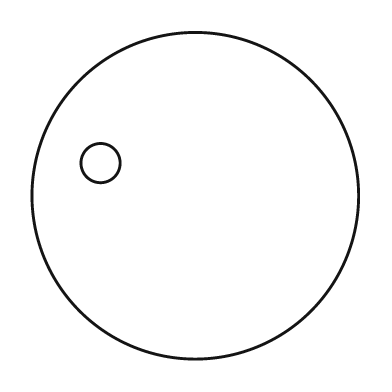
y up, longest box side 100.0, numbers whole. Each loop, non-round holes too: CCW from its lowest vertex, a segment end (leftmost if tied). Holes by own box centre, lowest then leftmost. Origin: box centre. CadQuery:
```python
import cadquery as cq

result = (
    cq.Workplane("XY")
    .moveTo(0.0, 0.0)
    .circle(50.0)
    .moveTo(-29.0, 10.0)
    .circle(6.0)
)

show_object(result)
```